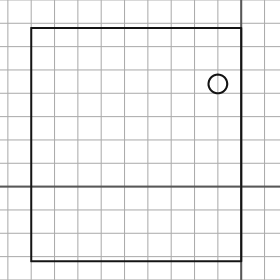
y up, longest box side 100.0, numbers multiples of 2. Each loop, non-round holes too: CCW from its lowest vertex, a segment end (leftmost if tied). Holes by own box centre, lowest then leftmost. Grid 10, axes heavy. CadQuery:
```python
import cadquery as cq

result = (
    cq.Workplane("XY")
    .moveTo(-90.0, -32.0)
    .lineTo(0.0, -32.0)
    .lineTo(0.0, 68.0)
    .lineTo(-90.0, 68.0)
    .close()
    .moveTo(-10.0, 44.0)
    .circle(4.0)
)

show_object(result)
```